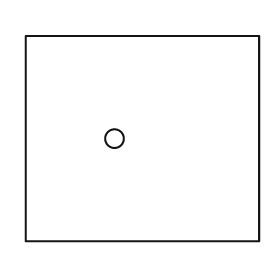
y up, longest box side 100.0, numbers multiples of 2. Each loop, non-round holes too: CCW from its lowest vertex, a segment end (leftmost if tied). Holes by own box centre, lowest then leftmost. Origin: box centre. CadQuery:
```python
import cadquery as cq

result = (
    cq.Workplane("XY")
    .moveTo(-50.0, -44.0)
    .lineTo(50.0, -44.0)
    .lineTo(50.0, 44.0)
    .lineTo(-50.0, 44.0)
    .close()
    .moveTo(-12.0, 0.0)
    .circle(4.0)
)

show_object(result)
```